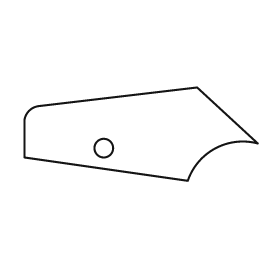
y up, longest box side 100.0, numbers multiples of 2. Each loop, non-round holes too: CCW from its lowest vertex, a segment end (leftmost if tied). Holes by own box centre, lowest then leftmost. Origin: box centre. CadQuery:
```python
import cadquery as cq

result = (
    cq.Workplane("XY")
    .moveTo(20.0, -20.0)
    .threePointArc((32.0, -6.0), (50.0, -4.0))
    .lineTo(24.0, 20.0)
    .lineTo(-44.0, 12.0)
    .threePointArc((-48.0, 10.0), (-50.0, 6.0))
    .lineTo(-50.0, -10.0)
    .close()
    .moveTo(-16.0, -6.0)
    .circle(4.0)
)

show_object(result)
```